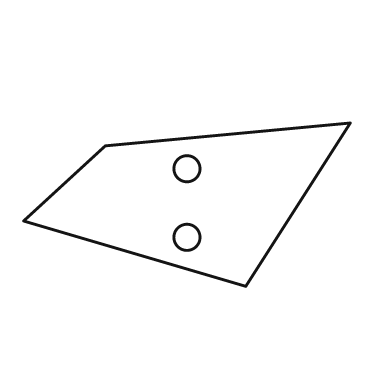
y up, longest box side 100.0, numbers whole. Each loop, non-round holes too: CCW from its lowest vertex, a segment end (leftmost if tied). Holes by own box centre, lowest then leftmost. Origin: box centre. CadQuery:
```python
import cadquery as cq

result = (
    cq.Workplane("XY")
    .moveTo(18.0, -25.0)
    .lineTo(50.0, 25.0)
    .lineTo(-25.0, 18.0)
    .lineTo(-50.0, -5.0)
    .close()
    .moveTo(0.0, -10.0)
    .circle(4.0)
    .moveTo(0.0, 11.0)
    .circle(4.0)
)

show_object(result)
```